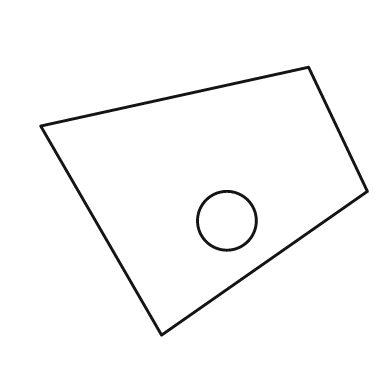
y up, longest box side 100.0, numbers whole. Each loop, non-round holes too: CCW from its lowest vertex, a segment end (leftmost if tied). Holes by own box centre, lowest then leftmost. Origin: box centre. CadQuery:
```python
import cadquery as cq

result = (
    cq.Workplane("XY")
    .moveTo(-13.0, -41.0)
    .lineTo(50.0, 3.0)
    .lineTo(32.0, 41.0)
    .lineTo(-50.0, 23.0)
    .close()
    .moveTo(7.0, -6.0)
    .circle(9.0)
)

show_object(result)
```